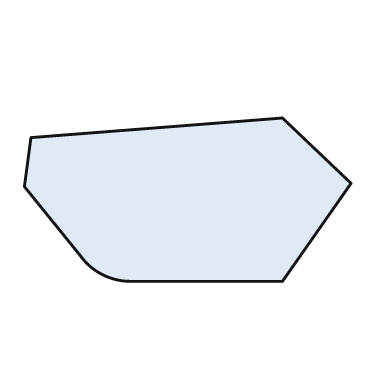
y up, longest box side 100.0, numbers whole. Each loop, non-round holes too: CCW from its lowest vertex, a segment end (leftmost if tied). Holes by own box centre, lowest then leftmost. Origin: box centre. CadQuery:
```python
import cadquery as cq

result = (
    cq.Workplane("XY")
    .moveTo(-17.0, -25.0)
    .lineTo(29.0, -25.0)
    .lineTo(50.0, 5.0)
    .lineTo(29.0, 25.0)
    .lineTo(-48.0, 19.0)
    .lineTo(-50.0, 4.0)
    .lineTo(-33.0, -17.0)
    .threePointArc((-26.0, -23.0), (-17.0, -25.0))
    .close()
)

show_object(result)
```